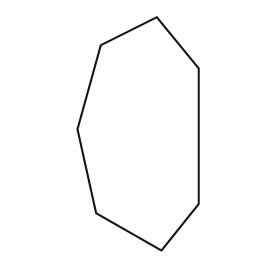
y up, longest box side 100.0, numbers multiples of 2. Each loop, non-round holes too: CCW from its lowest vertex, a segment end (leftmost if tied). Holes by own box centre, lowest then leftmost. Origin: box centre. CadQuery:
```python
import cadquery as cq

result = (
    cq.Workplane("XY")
    .moveTo(10.0, -50.0)
    .lineTo(26.0, -30.0)
    .lineTo(26.0, 28.0)
    .lineTo(8.0, 50.0)
    .lineTo(-16.0, 38.0)
    .lineTo(-26.0, 2.0)
    .lineTo(-18.0, -34.0)
    .close()
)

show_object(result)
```